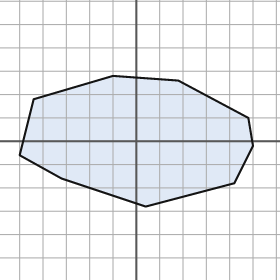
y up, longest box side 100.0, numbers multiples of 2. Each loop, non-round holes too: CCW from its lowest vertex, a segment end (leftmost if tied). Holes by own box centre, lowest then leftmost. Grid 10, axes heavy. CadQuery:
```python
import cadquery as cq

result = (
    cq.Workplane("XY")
    .moveTo(4.0, -28.0)
    .lineTo(42.0, -18.0)
    .lineTo(50.0, -2.0)
    .lineTo(48.0, 10.0)
    .lineTo(18.0, 26.0)
    .lineTo(-10.0, 28.0)
    .lineTo(-44.0, 18.0)
    .lineTo(-50.0, -6.0)
    .lineTo(-32.0, -16.0)
    .close()
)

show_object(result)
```